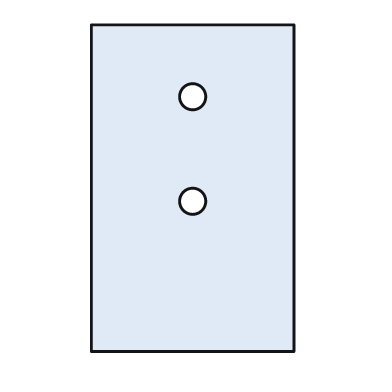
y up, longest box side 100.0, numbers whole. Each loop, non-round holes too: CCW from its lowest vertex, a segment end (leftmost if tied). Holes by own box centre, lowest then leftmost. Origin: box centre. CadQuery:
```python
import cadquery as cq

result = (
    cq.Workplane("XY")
    .moveTo(-31.0, -50.0)
    .lineTo(31.0, -50.0)
    .lineTo(31.0, 50.0)
    .lineTo(-31.0, 50.0)
    .close()
    .moveTo(0.0, -4.0)
    .circle(4.0)
    .moveTo(0.0, 28.0)
    .circle(4.0)
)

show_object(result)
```